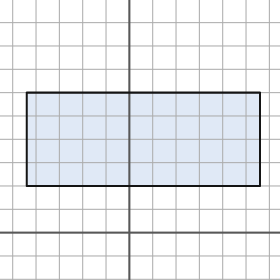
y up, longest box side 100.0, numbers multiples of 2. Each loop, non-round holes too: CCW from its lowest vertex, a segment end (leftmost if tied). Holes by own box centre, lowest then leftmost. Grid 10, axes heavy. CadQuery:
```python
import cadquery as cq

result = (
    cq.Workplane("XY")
    .moveTo(-44.0, 20.0)
    .lineTo(56.0, 20.0)
    .lineTo(56.0, 60.0)
    .lineTo(-44.0, 60.0)
    .close()
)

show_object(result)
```